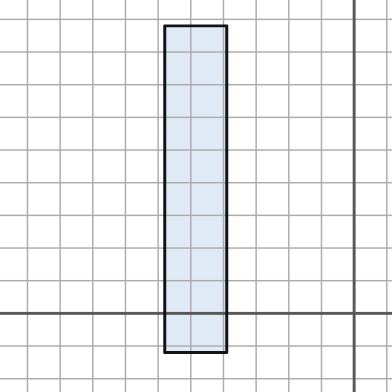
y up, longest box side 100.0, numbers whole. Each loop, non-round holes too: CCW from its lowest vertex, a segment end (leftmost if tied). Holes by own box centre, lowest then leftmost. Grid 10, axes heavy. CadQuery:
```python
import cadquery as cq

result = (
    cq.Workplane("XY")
    .moveTo(-58.0, -12.0)
    .lineTo(-39.0, -12.0)
    .lineTo(-39.0, 88.0)
    .lineTo(-58.0, 88.0)
    .close()
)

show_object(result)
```